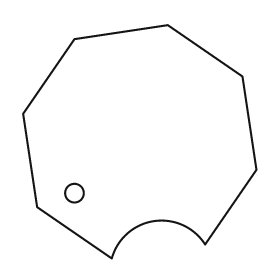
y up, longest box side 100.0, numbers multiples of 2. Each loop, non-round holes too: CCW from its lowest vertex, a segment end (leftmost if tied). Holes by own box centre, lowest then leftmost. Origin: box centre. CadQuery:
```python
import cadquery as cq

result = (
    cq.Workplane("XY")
    .moveTo(-12.0, -50.0)
    .threePointArc((6.0, -34.0), (28.0, -44.0))
    .lineTo(50.0, -12.0)
    .lineTo(44.0, 28.0)
    .lineTo(12.0, 50.0)
    .lineTo(-28.0, 44.0)
    .lineTo(-50.0, 12.0)
    .lineTo(-44.0, -28.0)
    .close()
    .moveTo(-28.0, -22.0)
    .circle(4.0)
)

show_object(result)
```